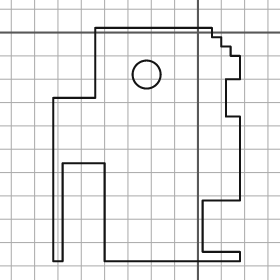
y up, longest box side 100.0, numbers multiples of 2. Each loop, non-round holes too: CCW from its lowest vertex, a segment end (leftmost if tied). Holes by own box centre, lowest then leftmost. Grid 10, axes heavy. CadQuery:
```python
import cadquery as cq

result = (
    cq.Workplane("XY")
    .moveTo(-62.0, -98.0)
    .lineTo(-58.0, -98.0)
    .lineTo(-58.0, -56.0)
    .lineTo(-40.0, -56.0)
    .lineTo(-40.0, -98.0)
    .lineTo(18.0, -98.0)
    .lineTo(18.0, -94.0)
    .lineTo(2.0, -94.0)
    .lineTo(2.0, -72.0)
    .lineTo(18.0, -72.0)
    .lineTo(18.0, -36.0)
    .lineTo(12.0, -36.0)
    .lineTo(12.0, -20.0)
    .lineTo(18.0, -20.0)
    .lineTo(18.0, -10.0)
    .lineTo(14.0, -10.0)
    .lineTo(14.0, -6.0)
    .lineTo(10.0, -6.0)
    .lineTo(10.0, -2.0)
    .lineTo(6.0, -2.0)
    .lineTo(6.0, 2.0)
    .lineTo(-44.0, 2.0)
    .lineTo(-44.0, -28.0)
    .lineTo(-62.0, -28.0)
    .close()
    .moveTo(-22.0, -18.0)
    .circle(6.0)
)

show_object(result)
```